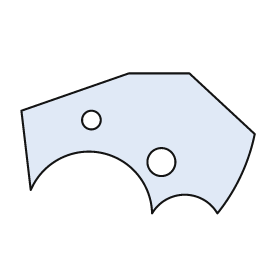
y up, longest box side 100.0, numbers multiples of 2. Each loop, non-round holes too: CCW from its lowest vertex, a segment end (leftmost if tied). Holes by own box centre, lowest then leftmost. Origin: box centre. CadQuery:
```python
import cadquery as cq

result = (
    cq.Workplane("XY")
    .moveTo(6.0, -30.0)
    .threePointArc((20.0, -22.0), (34.0, -30.0))
    .threePointArc((44.0, -14.0), (50.0, 4.0))
    .lineTo(22.0, 30.0)
    .lineTo(-4.0, 30.0)
    .lineTo(-50.0, 14.0)
    .lineTo(-46.0, -20.0)
    .threePointArc((-16.0, -4.0), (6.0, -30.0))
    .close()
    .moveTo(10.0, -8.0)
    .circle(6.0)
    .moveTo(-20.0, 10.0)
    .circle(4.0)
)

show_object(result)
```